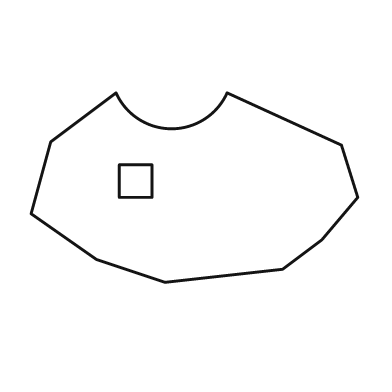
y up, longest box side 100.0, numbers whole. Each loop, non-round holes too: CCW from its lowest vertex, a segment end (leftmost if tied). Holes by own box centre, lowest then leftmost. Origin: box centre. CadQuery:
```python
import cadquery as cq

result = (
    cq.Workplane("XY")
    .moveTo(-9.0, -29.0)
    .lineTo(27.0, -25.0)
    .lineTo(39.0, -16.0)
    .lineTo(50.0, -3.0)
    .lineTo(45.0, 13.0)
    .lineTo(10.0, 29.0)
    .threePointArc((-7.0, 18.0), (-24.0, 29.0))
    .lineTo(-44.0, 14.0)
    .lineTo(-50.0, -8.0)
    .lineTo(-30.0, -22.0)
    .close()
    .moveTo(-23.0, -3.0)
    .lineTo(-13.0, -3.0)
    .lineTo(-13.0, 7.0)
    .lineTo(-23.0, 7.0)
    .close()
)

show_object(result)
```